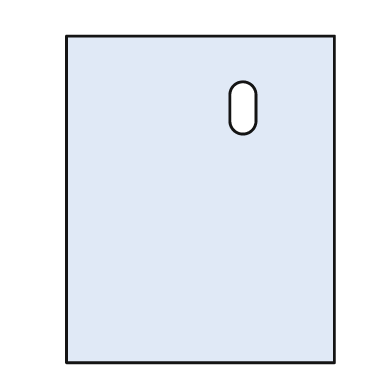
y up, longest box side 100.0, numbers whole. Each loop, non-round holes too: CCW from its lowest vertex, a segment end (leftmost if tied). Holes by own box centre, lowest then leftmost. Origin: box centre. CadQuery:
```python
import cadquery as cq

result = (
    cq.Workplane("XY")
    .moveTo(-41.0, -50.0)
    .lineTo(41.0, -50.0)
    .lineTo(41.0, 50.0)
    .lineTo(-41.0, 50.0)
    .close()
    .moveTo(9.0, 24.0)
    .threePointArc((13.0, 20.0), (17.0, 24.0))
    .lineTo(17.0, 32.0)
    .threePointArc((13.0, 36.0), (9.0, 32.0))
    .close()
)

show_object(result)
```